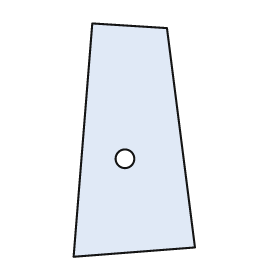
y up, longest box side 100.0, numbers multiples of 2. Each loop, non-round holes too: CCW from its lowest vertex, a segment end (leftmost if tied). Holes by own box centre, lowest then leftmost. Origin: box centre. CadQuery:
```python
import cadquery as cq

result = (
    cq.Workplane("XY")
    .moveTo(-26.0, -50.0)
    .lineTo(26.0, -46.0)
    .lineTo(14.0, 48.0)
    .lineTo(-18.0, 50.0)
    .close()
    .moveTo(-4.0, -8.0)
    .circle(4.0)
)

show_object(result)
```